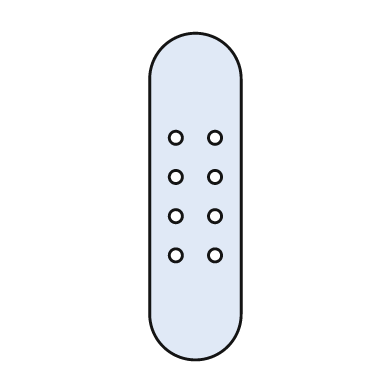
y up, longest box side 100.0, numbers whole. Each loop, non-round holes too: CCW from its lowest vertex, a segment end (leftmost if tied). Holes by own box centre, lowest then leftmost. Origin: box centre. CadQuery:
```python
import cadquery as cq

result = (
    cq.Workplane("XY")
    .moveTo(-14.0, -36.0)
    .threePointArc((0.0, -50.0), (14.0, -36.0))
    .lineTo(14.0, 36.0)
    .threePointArc((0.0, 50.0), (-14.0, 36.0))
    .close()
    .moveTo(-6.0, -18.0)
    .circle(2.0)
    .moveTo(6.0, -18.0)
    .circle(2.0)
    .moveTo(-6.0, -6.0)
    .circle(2.0)
    .moveTo(6.0, -6.0)
    .circle(2.0)
    .moveTo(-6.0, 6.0)
    .circle(2.0)
    .moveTo(6.0, 6.0)
    .circle(2.0)
    .moveTo(-6.0, 18.0)
    .circle(2.0)
    .moveTo(6.0, 18.0)
    .circle(2.0)
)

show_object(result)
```